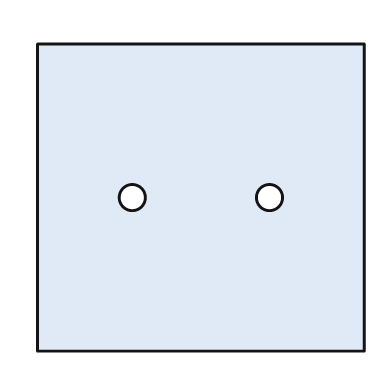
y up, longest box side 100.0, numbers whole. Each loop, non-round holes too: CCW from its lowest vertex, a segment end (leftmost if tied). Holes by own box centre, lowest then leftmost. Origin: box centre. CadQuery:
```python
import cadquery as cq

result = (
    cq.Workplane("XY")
    .moveTo(-50.0, -47.0)
    .lineTo(50.0, -47.0)
    .lineTo(50.0, 47.0)
    .lineTo(-50.0, 47.0)
    .close()
    .moveTo(-21.0, 0.0)
    .circle(4.0)
    .moveTo(21.0, 0.0)
    .circle(4.0)
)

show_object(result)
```